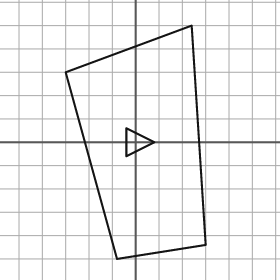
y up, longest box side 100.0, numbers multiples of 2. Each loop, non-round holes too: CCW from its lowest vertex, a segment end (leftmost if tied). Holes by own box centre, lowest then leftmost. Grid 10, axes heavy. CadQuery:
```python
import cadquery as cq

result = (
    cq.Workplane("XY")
    .moveTo(-8.0, -50.0)
    .lineTo(30.0, -44.0)
    .lineTo(24.0, 50.0)
    .lineTo(-30.0, 30.0)
    .close()
    .moveTo(-4.0, -6.0)
    .lineTo(8.0, 0.0)
    .lineTo(-4.0, 6.0)
    .close()
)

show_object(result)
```